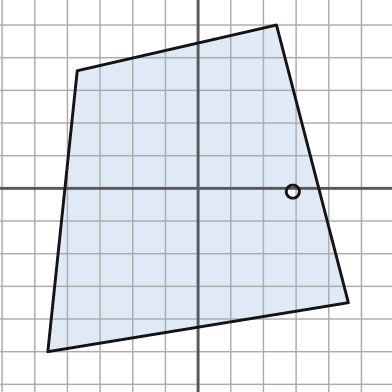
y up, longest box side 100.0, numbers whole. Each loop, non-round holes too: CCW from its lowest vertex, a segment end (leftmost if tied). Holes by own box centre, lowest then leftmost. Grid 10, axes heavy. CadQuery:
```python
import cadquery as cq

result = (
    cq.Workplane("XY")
    .moveTo(-46.0, -50.0)
    .lineTo(46.0, -35.0)
    .lineTo(24.0, 50.0)
    .lineTo(-37.0, 36.0)
    .close()
    .moveTo(29.0, -1.0)
    .circle(2.0)
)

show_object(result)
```